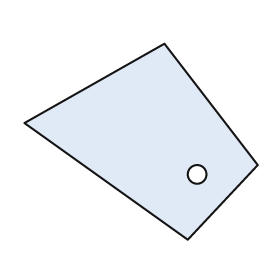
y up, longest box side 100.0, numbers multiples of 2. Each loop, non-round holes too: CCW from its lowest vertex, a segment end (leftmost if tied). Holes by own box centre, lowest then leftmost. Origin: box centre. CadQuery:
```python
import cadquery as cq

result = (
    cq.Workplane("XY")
    .moveTo(20.0, -42.0)
    .lineTo(50.0, -10.0)
    .lineTo(10.0, 42.0)
    .lineTo(-50.0, 8.0)
    .close()
    .moveTo(24.0, -14.0)
    .circle(4.0)
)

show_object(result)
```